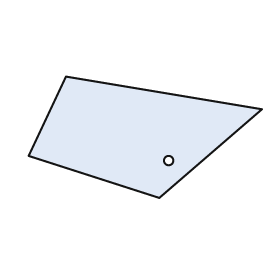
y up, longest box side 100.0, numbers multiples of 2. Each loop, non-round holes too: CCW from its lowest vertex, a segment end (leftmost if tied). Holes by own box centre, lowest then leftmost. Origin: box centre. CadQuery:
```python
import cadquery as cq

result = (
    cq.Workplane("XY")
    .moveTo(6.0, -26.0)
    .lineTo(50.0, 12.0)
    .lineTo(-34.0, 26.0)
    .lineTo(-50.0, -8.0)
    .close()
    .moveTo(10.0, -10.0)
    .circle(2.0)
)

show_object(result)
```